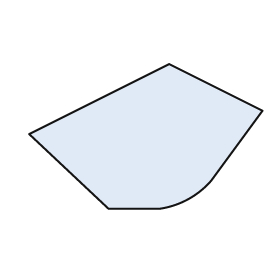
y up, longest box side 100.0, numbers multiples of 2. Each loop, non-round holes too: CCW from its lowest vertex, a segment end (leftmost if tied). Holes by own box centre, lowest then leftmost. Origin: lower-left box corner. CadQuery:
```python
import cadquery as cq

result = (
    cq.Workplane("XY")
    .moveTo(34.0, 0.0)
    .lineTo(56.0, 0.0)
    .threePointArc((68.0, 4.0), (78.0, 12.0))
    .lineTo(100.0, 42.0)
    .lineTo(60.0, 62.0)
    .lineTo(0.0, 32.0)
    .close()
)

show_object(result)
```